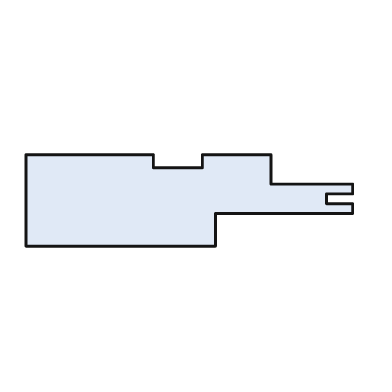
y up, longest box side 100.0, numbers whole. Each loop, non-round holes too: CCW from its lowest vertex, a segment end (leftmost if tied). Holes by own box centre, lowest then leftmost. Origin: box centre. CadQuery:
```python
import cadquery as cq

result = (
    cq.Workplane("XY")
    .moveTo(-50.0, -14.0)
    .lineTo(8.0, -14.0)
    .lineTo(8.0, -4.0)
    .lineTo(50.0, -4.0)
    .lineTo(50.0, -1.0)
    .lineTo(42.0, -1.0)
    .lineTo(42.0, 2.0)
    .lineTo(50.0, 2.0)
    .lineTo(50.0, 5.0)
    .lineTo(25.0, 5.0)
    .lineTo(25.0, 14.0)
    .lineTo(4.0, 14.0)
    .lineTo(4.0, 10.0)
    .lineTo(-11.0, 10.0)
    .lineTo(-11.0, 14.0)
    .lineTo(-50.0, 14.0)
    .close()
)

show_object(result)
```